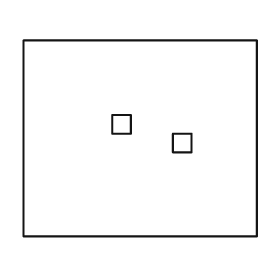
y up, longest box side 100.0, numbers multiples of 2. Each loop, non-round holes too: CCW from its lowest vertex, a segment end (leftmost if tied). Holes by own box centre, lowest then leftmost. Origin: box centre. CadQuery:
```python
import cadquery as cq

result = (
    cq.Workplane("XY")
    .moveTo(-50.0, -42.0)
    .lineTo(50.0, -42.0)
    .lineTo(50.0, 42.0)
    .lineTo(-50.0, 42.0)
    .close()
    .moveTo(14.0, -6.0)
    .lineTo(22.0, -6.0)
    .lineTo(22.0, 2.0)
    .lineTo(14.0, 2.0)
    .close()
    .moveTo(-12.0, 2.0)
    .lineTo(-4.0, 2.0)
    .lineTo(-4.0, 10.0)
    .lineTo(-12.0, 10.0)
    .close()
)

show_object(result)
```